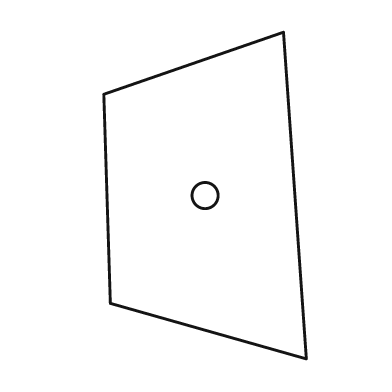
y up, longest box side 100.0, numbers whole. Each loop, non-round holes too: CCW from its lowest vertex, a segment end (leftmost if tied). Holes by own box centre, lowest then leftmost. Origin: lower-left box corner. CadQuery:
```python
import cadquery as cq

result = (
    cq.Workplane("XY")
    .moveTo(62.0, 0.0)
    .lineTo(55.0, 100.0)
    .lineTo(0.0, 81.0)
    .lineTo(2.0, 17.0)
    .close()
    .moveTo(31.0, 50.0)
    .circle(4.0)
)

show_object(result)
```